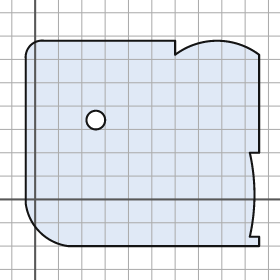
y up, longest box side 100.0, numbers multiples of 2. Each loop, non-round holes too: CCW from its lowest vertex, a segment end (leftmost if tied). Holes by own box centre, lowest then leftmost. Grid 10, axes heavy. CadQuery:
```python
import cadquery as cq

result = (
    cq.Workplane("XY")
    .moveTo(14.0, -20.0)
    .lineTo(96.0, -20.0)
    .lineTo(96.0, -16.0)
    .lineTo(92.0, -16.0)
    .threePointArc((94.0, 2.0), (92.0, 20.0))
    .lineTo(96.0, 20.0)
    .lineTo(96.0, 62.0)
    .threePointArc((78.0, 68.0), (60.0, 62.0))
    .lineTo(60.0, 68.0)
    .lineTo(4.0, 68.0)
    .threePointArc((-2.0, 66.0), (-4.0, 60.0))
    .lineTo(-4.0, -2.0)
    .threePointArc((2.0, -14.0), (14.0, -20.0))
    .close()
    .moveTo(26.0, 34.0)
    .circle(4.0)
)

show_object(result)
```